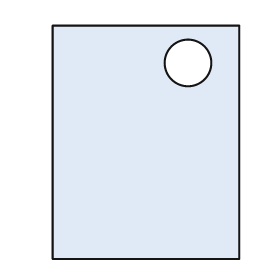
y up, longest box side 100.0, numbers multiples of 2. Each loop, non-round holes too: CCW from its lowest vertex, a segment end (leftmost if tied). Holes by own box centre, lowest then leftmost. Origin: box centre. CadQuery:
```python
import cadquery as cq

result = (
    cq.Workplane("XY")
    .moveTo(-40.0, -50.0)
    .lineTo(40.0, -50.0)
    .lineTo(40.0, 50.0)
    .lineTo(-40.0, 50.0)
    .close()
    .moveTo(18.0, 34.0)
    .circle(10.0)
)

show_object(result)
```